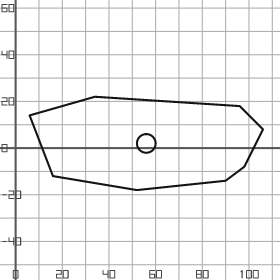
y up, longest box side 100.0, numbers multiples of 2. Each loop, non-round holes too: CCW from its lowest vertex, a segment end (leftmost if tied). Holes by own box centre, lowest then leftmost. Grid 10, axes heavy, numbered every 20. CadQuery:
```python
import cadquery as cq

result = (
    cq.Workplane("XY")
    .moveTo(52.0, -18.0)
    .lineTo(90.0, -14.0)
    .lineTo(98.0, -8.0)
    .lineTo(106.0, 8.0)
    .lineTo(96.0, 18.0)
    .lineTo(34.0, 22.0)
    .lineTo(6.0, 14.0)
    .lineTo(16.0, -12.0)
    .close()
    .moveTo(56.0, 2.0)
    .circle(4.0)
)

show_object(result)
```